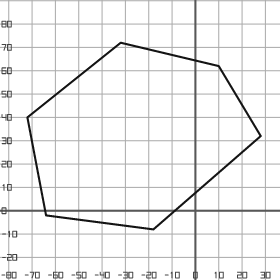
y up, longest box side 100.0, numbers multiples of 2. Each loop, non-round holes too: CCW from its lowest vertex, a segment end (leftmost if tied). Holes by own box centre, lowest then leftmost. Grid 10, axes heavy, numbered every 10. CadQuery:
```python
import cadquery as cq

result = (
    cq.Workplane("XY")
    .moveTo(-18.0, -8.0)
    .lineTo(28.0, 32.0)
    .lineTo(10.0, 62.0)
    .lineTo(-32.0, 72.0)
    .lineTo(-72.0, 40.0)
    .lineTo(-64.0, -2.0)
    .close()
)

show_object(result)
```